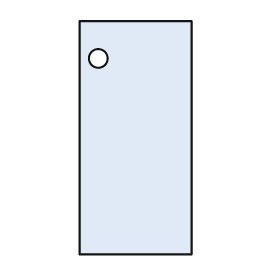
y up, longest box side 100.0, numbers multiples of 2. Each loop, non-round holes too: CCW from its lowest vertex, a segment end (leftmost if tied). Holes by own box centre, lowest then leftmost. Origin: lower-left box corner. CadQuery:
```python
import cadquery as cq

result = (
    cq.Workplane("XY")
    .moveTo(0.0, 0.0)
    .lineTo(48.0, 0.0)
    .lineTo(48.0, 100.0)
    .lineTo(0.0, 100.0)
    .close()
    .moveTo(8.0, 84.0)
    .circle(4.0)
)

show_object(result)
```